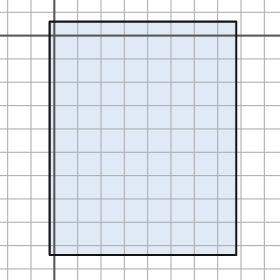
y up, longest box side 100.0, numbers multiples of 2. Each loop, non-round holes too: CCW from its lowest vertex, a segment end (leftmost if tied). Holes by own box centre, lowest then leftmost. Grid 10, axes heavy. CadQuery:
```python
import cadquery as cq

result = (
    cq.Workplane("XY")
    .moveTo(-2.0, -94.0)
    .lineTo(78.0, -94.0)
    .lineTo(78.0, 6.0)
    .lineTo(-2.0, 6.0)
    .close()
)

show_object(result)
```